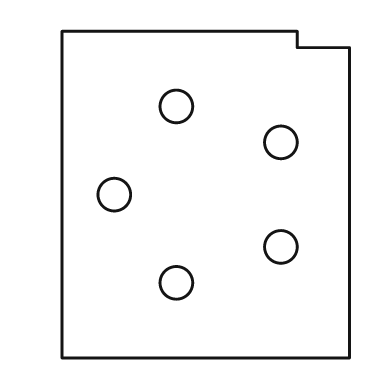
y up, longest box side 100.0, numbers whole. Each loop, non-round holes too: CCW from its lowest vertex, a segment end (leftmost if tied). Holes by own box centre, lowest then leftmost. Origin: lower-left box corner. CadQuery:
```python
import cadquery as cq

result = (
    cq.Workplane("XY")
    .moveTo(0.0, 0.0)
    .lineTo(88.0, 0.0)
    .lineTo(88.0, 95.0)
    .lineTo(72.0, 95.0)
    .lineTo(72.0, 100.0)
    .lineTo(0.0, 100.0)
    .close()
    .moveTo(35.0, 23.0)
    .circle(5.0)
    .moveTo(67.0, 34.0)
    .circle(5.0)
    .moveTo(16.0, 50.0)
    .circle(5.0)
    .moveTo(67.0, 66.0)
    .circle(5.0)
    .moveTo(35.0, 77.0)
    .circle(5.0)
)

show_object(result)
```